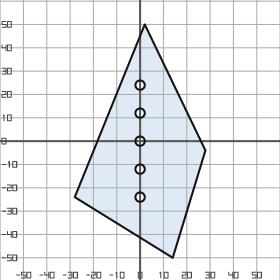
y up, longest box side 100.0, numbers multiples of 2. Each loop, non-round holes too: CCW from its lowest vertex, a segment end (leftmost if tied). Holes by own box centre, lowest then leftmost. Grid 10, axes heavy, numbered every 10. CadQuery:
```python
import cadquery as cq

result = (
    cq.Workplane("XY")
    .moveTo(14.0, -50.0)
    .lineTo(28.0, -4.0)
    .lineTo(2.0, 50.0)
    .lineTo(-28.0, -24.0)
    .close()
    .moveTo(0.0, -24.0)
    .circle(2.0)
    .moveTo(0.0, -12.0)
    .circle(2.0)
    .moveTo(0.0, 0.0)
    .circle(2.0)
    .moveTo(0.0, 12.0)
    .circle(2.0)
    .moveTo(0.0, 24.0)
    .circle(2.0)
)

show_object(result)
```